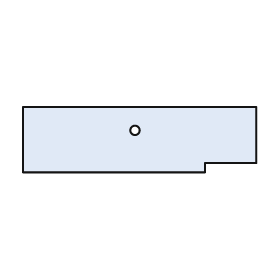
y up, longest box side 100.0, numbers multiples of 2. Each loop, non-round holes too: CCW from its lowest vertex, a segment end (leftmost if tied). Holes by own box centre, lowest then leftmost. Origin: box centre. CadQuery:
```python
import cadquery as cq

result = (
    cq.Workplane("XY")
    .moveTo(-50.0, -14.0)
    .lineTo(28.0, -14.0)
    .lineTo(28.0, -10.0)
    .lineTo(50.0, -10.0)
    .lineTo(50.0, 14.0)
    .lineTo(-50.0, 14.0)
    .close()
    .moveTo(-2.0, 4.0)
    .circle(2.0)
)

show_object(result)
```